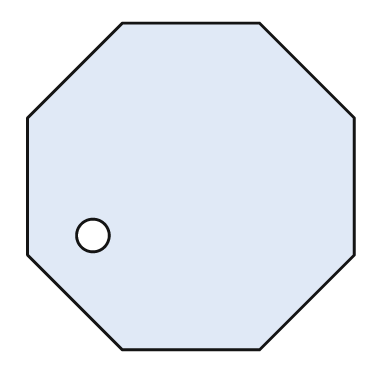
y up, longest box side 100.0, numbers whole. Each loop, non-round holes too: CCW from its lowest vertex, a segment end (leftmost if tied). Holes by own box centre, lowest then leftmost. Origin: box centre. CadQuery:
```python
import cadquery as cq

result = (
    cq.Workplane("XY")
    .moveTo(-21.0, -50.0)
    .lineTo(21.0, -50.0)
    .lineTo(50.0, -21.0)
    .lineTo(50.0, 21.0)
    .lineTo(21.0, 50.0)
    .lineTo(-21.0, 50.0)
    .lineTo(-50.0, 21.0)
    .lineTo(-50.0, -21.0)
    .close()
    .moveTo(-30.0, -15.0)
    .circle(5.0)
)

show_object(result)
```